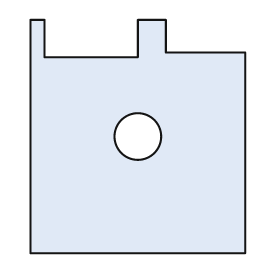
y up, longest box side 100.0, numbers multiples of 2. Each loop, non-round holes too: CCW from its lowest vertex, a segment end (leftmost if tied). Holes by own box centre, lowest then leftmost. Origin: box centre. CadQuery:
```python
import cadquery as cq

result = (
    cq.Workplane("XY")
    .moveTo(-46.0, -50.0)
    .lineTo(46.0, -50.0)
    .lineTo(46.0, 36.0)
    .lineTo(12.0, 36.0)
    .lineTo(12.0, 50.0)
    .lineTo(0.0, 50.0)
    .lineTo(0.0, 34.0)
    .lineTo(-40.0, 34.0)
    .lineTo(-40.0, 50.0)
    .lineTo(-46.0, 50.0)
    .close()
    .moveTo(0.0, 0.0)
    .circle(10.0)
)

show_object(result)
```